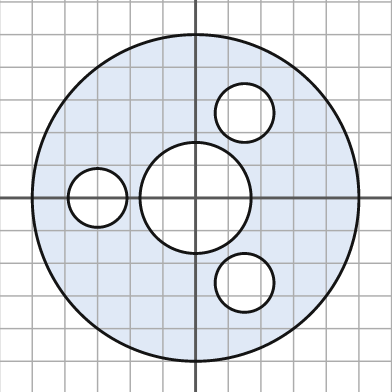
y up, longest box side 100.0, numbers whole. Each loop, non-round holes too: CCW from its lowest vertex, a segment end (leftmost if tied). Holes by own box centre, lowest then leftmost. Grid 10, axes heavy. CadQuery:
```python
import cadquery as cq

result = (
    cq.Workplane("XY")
    .moveTo(0.0, 0.0)
    .circle(50.0)
    .moveTo(15.0, -26.0)
    .circle(9.0)
    .moveTo(-30.0, 0.0)
    .circle(9.0)
    .moveTo(0.0, 0.0)
    .circle(17.0)
    .moveTo(15.0, 26.0)
    .circle(9.0)
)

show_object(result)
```